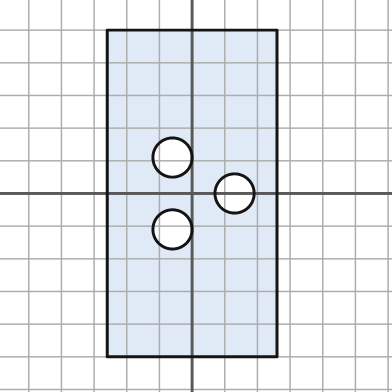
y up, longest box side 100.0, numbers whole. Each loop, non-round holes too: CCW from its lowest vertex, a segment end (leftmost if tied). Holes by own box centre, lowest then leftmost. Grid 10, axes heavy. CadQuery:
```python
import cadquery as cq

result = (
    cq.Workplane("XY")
    .moveTo(-26.0, -50.0)
    .lineTo(26.0, -50.0)
    .lineTo(26.0, 50.0)
    .lineTo(-26.0, 50.0)
    .close()
    .moveTo(-6.0, -11.0)
    .circle(6.0)
    .moveTo(13.0, 0.0)
    .circle(6.0)
    .moveTo(-6.0, 11.0)
    .circle(6.0)
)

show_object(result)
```